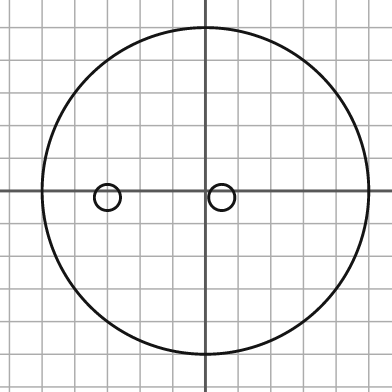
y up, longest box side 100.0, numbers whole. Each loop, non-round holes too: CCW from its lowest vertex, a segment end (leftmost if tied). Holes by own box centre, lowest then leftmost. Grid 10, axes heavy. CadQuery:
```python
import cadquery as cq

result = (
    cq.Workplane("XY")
    .moveTo(0.0, 0.0)
    .circle(50.0)
    .moveTo(-30.0, -2.0)
    .circle(4.0)
    .moveTo(5.0, -2.0)
    .circle(4.0)
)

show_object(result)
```